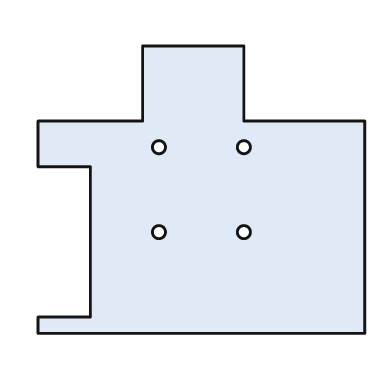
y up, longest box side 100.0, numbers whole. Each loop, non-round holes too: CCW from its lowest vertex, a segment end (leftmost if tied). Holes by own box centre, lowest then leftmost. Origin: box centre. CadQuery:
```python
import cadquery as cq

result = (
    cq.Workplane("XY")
    .moveTo(-50.0, -44.0)
    .lineTo(50.0, -44.0)
    .lineTo(50.0, 21.0)
    .lineTo(13.0, 21.0)
    .lineTo(13.0, 44.0)
    .lineTo(-18.0, 44.0)
    .lineTo(-18.0, 21.0)
    .lineTo(-50.0, 21.0)
    .lineTo(-50.0, 7.0)
    .lineTo(-34.0, 7.0)
    .lineTo(-34.0, -39.0)
    .lineTo(-50.0, -39.0)
    .close()
    .moveTo(-13.0, -13.0)
    .circle(2.0)
    .moveTo(13.0, -13.0)
    .circle(2.0)
    .moveTo(-13.0, 13.0)
    .circle(2.0)
    .moveTo(13.0, 13.0)
    .circle(2.0)
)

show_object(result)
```